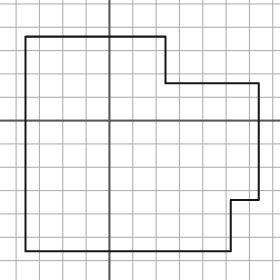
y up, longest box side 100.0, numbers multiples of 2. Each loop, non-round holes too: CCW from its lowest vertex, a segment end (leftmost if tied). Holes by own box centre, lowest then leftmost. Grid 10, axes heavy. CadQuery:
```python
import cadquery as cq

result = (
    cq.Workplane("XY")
    .moveTo(-36.0, -56.0)
    .lineTo(52.0, -56.0)
    .lineTo(52.0, -34.0)
    .lineTo(64.0, -34.0)
    .lineTo(64.0, 16.0)
    .lineTo(24.0, 16.0)
    .lineTo(24.0, 36.0)
    .lineTo(-36.0, 36.0)
    .close()
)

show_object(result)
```